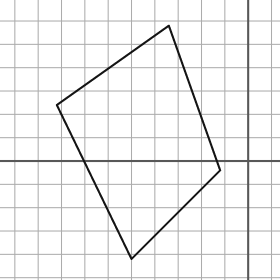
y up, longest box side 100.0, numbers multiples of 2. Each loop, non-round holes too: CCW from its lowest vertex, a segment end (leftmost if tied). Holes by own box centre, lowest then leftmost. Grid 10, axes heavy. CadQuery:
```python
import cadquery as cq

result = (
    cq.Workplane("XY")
    .moveTo(-50.0, -42.0)
    .lineTo(-12.0, -4.0)
    .lineTo(-34.0, 58.0)
    .lineTo(-82.0, 24.0)
    .close()
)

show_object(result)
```